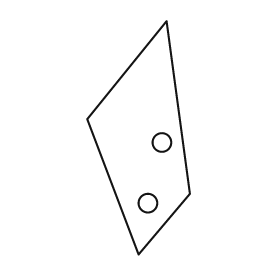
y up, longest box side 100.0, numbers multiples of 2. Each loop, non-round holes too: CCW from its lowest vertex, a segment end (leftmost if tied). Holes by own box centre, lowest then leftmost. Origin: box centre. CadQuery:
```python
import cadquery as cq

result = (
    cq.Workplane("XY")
    .moveTo(0.0, -50.0)
    .lineTo(22.0, -24.0)
    .lineTo(12.0, 50.0)
    .lineTo(-22.0, 8.0)
    .close()
    .moveTo(4.0, -28.0)
    .circle(4.0)
    .moveTo(10.0, -2.0)
    .circle(4.0)
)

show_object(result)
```